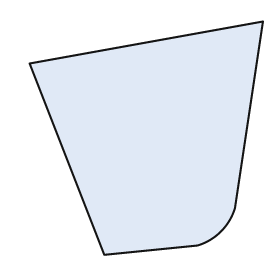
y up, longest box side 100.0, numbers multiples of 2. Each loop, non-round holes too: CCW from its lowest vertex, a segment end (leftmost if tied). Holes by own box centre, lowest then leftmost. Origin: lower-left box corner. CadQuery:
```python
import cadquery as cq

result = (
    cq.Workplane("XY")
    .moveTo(32.0, 0.0)
    .lineTo(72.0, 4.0)
    .threePointArc((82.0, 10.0), (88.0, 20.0))
    .lineTo(100.0, 100.0)
    .lineTo(0.0, 82.0)
    .close()
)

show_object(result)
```